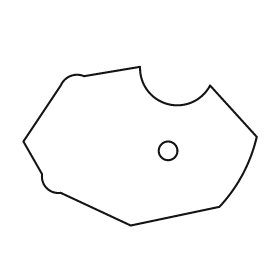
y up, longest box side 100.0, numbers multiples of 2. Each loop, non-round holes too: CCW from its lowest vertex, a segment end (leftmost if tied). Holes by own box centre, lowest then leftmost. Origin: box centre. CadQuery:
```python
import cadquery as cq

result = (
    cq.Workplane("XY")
    .moveTo(-4.0, -34.0)
    .lineTo(34.0, -26.0)
    .threePointArc((44.0, -12.0), (50.0, 4.0))
    .lineTo(30.0, 26.0)
    .threePointArc((12.0, 18.0), (0.0, 34.0))
    .lineTo(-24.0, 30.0)
    .threePointArc((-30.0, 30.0), (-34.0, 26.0))
    .lineTo(-50.0, 2.0)
    .lineTo(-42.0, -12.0)
    .threePointArc((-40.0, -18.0), (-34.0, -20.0))
    .close()
    .moveTo(12.0, -2.0)
    .circle(4.0)
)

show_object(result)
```